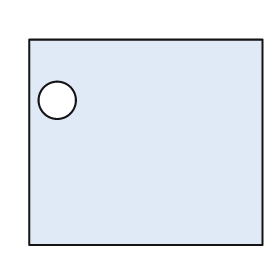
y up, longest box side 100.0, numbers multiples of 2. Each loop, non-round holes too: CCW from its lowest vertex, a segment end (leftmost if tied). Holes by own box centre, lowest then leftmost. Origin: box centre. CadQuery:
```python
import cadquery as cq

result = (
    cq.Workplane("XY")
    .moveTo(-50.0, -44.0)
    .lineTo(50.0, -44.0)
    .lineTo(50.0, 44.0)
    .lineTo(-50.0, 44.0)
    .close()
    .moveTo(-38.0, 18.0)
    .circle(8.0)
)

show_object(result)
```